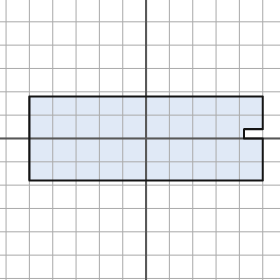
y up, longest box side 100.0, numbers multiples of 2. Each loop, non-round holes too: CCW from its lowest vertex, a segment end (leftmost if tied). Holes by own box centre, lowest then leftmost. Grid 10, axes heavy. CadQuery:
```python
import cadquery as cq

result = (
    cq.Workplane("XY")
    .moveTo(-50.0, -18.0)
    .lineTo(50.0, -18.0)
    .lineTo(50.0, 0.0)
    .lineTo(42.0, 0.0)
    .lineTo(42.0, 4.0)
    .lineTo(50.0, 4.0)
    .lineTo(50.0, 18.0)
    .lineTo(-50.0, 18.0)
    .close()
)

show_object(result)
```